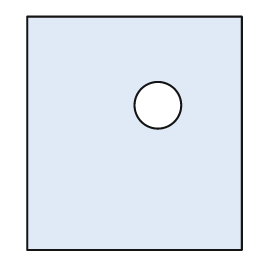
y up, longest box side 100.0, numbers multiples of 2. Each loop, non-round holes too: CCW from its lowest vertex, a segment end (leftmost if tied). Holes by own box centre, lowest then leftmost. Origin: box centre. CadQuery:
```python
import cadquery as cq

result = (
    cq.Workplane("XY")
    .moveTo(-46.0, -50.0)
    .lineTo(46.0, -50.0)
    .lineTo(46.0, 50.0)
    .lineTo(-46.0, 50.0)
    .close()
    .moveTo(10.0, 12.0)
    .circle(10.0)
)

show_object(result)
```